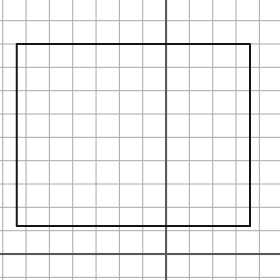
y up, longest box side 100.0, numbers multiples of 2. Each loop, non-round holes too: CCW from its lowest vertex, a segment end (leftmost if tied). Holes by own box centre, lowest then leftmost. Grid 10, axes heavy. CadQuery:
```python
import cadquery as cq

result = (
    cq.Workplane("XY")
    .moveTo(-64.0, 12.0)
    .lineTo(36.0, 12.0)
    .lineTo(36.0, 90.0)
    .lineTo(-64.0, 90.0)
    .close()
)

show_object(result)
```